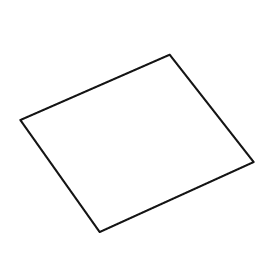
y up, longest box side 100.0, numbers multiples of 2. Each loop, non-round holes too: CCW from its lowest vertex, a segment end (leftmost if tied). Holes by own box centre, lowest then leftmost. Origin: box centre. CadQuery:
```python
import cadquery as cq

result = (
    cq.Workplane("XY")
    .moveTo(-16.0, -38.0)
    .lineTo(50.0, -8.0)
    .lineTo(14.0, 38.0)
    .lineTo(-50.0, 10.0)
    .close()
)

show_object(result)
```